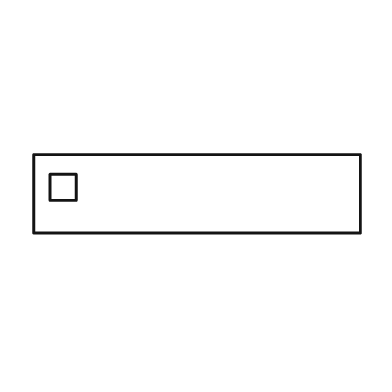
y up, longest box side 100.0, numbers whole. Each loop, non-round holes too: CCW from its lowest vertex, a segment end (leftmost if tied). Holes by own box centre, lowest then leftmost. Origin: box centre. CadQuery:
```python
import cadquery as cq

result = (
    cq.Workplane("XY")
    .moveTo(-50.0, -12.0)
    .lineTo(50.0, -12.0)
    .lineTo(50.0, 12.0)
    .lineTo(-50.0, 12.0)
    .close()
    .moveTo(-45.0, -2.0)
    .lineTo(-37.0, -2.0)
    .lineTo(-37.0, 6.0)
    .lineTo(-45.0, 6.0)
    .close()
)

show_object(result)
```